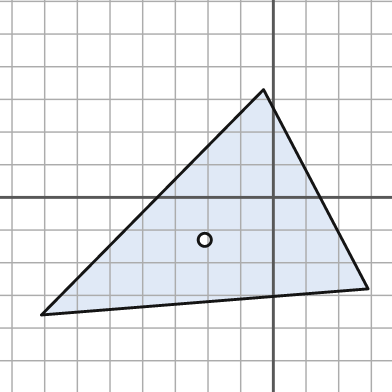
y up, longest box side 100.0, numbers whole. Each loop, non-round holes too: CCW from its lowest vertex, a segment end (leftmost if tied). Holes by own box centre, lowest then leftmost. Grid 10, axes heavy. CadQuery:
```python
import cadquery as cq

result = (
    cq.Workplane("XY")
    .moveTo(-71.0, -36.0)
    .lineTo(29.0, -28.0)
    .lineTo(-3.0, 33.0)
    .close()
    .moveTo(-21.0, -13.0)
    .circle(2.0)
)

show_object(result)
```